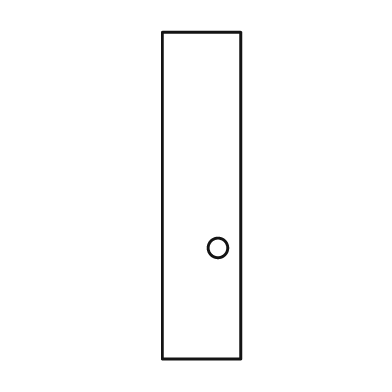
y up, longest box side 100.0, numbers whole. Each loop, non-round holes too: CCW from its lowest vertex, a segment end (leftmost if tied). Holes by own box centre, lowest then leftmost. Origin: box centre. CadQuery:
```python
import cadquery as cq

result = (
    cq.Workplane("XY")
    .moveTo(-12.0, -50.0)
    .lineTo(12.0, -50.0)
    .lineTo(12.0, 50.0)
    .lineTo(-12.0, 50.0)
    .close()
    .moveTo(5.0, -16.0)
    .circle(3.0)
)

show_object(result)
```